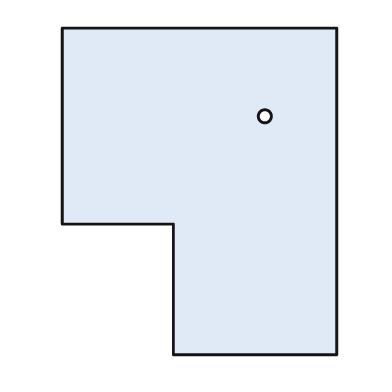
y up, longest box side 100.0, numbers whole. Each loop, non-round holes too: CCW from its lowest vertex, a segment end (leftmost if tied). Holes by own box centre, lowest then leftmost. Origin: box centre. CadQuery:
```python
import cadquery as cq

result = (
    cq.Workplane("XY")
    .moveTo(-8.0, -50.0)
    .lineTo(42.0, -50.0)
    .lineTo(42.0, 50.0)
    .lineTo(-42.0, 50.0)
    .lineTo(-42.0, -10.0)
    .lineTo(-8.0, -10.0)
    .close()
    .moveTo(20.0, 23.0)
    .circle(2.0)
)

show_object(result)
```